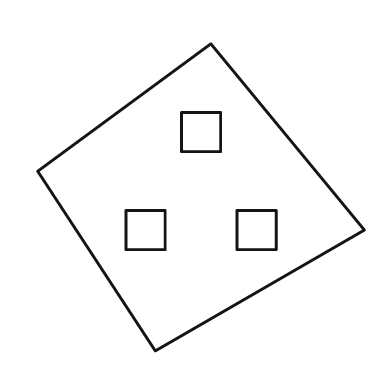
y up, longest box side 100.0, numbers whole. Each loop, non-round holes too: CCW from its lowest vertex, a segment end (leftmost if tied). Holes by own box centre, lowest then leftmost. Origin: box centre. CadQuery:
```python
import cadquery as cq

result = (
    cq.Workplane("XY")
    .moveTo(-14.0, -47.0)
    .lineTo(50.0, -10.0)
    .lineTo(3.0, 47.0)
    .lineTo(-50.0, 8.0)
    .close()
    .moveTo(-23.0, -16.0)
    .lineTo(-11.0, -16.0)
    .lineTo(-11.0, -4.0)
    .lineTo(-23.0, -4.0)
    .close()
    .moveTo(11.0, -16.0)
    .lineTo(23.0, -16.0)
    .lineTo(23.0, -4.0)
    .lineTo(11.0, -4.0)
    .close()
    .moveTo(-6.0, 14.0)
    .lineTo(6.0, 14.0)
    .lineTo(6.0, 26.0)
    .lineTo(-6.0, 26.0)
    .close()
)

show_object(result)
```